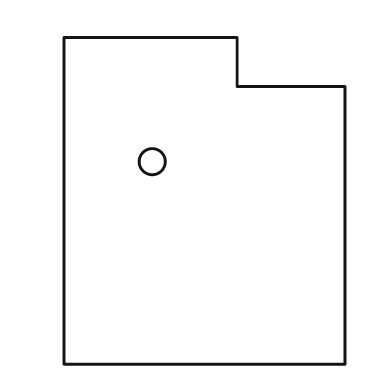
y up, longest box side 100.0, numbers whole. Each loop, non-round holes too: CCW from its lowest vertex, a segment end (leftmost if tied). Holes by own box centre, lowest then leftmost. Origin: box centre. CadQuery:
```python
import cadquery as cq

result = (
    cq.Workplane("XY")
    .moveTo(-43.0, -50.0)
    .lineTo(43.0, -50.0)
    .lineTo(43.0, 35.0)
    .lineTo(10.0, 35.0)
    .lineTo(10.0, 50.0)
    .lineTo(-43.0, 50.0)
    .close()
    .moveTo(-16.0, 12.0)
    .circle(4.0)
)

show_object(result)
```